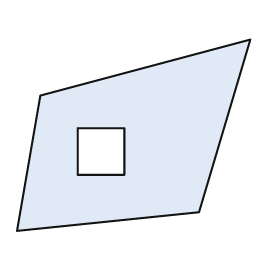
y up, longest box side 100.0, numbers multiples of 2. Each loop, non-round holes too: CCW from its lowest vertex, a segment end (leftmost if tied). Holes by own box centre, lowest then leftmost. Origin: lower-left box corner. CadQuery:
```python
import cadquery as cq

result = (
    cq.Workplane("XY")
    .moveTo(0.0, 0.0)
    .lineTo(78.0, 8.0)
    .lineTo(100.0, 82.0)
    .lineTo(10.0, 58.0)
    .close()
    .moveTo(26.0, 24.0)
    .lineTo(46.0, 24.0)
    .lineTo(46.0, 44.0)
    .lineTo(26.0, 44.0)
    .close()
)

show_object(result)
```